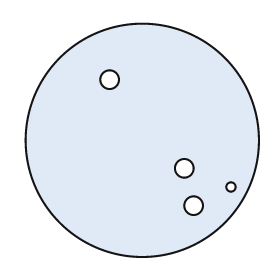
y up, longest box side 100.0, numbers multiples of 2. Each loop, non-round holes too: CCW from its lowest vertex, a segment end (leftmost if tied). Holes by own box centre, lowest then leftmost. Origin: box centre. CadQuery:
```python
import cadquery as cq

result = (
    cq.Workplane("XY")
    .moveTo(0.0, 0.0)
    .circle(50.0)
    .moveTo(22.0, -28.0)
    .circle(4.0)
    .moveTo(38.0, -20.0)
    .circle(2.0)
    .moveTo(18.0, -12.0)
    .circle(4.0)
    .moveTo(-14.0, 26.0)
    .circle(4.0)
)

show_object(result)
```